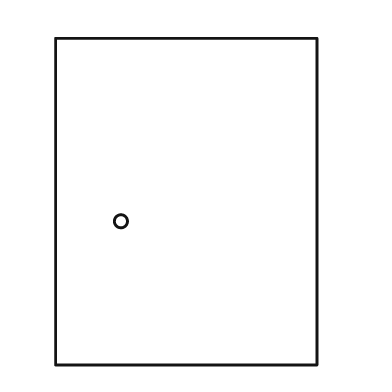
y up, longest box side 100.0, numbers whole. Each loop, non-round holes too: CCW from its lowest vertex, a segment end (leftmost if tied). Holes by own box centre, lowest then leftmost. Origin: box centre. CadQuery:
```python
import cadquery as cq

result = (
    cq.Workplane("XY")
    .moveTo(-40.0, -50.0)
    .lineTo(40.0, -50.0)
    .lineTo(40.0, 50.0)
    .lineTo(-40.0, 50.0)
    .close()
    .moveTo(-20.0, -6.0)
    .circle(2.0)
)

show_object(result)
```